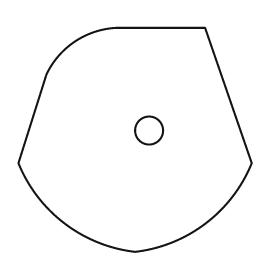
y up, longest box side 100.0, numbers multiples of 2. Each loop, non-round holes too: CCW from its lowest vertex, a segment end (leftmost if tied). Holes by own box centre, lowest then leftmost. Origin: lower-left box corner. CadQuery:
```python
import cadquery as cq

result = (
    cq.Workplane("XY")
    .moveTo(50.0, 0.0)
    .threePointArc((80.0, 12.0), (100.0, 38.0))
    .lineTo(80.0, 96.0)
    .lineTo(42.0, 96.0)
    .threePointArc((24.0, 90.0), (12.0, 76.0))
    .lineTo(0.0, 38.0)
    .threePointArc((20.0, 12.0), (50.0, 0.0))
    .close()
    .moveTo(56.0, 52.0)
    .circle(6.0)
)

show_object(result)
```